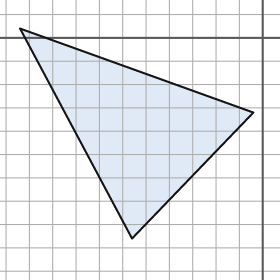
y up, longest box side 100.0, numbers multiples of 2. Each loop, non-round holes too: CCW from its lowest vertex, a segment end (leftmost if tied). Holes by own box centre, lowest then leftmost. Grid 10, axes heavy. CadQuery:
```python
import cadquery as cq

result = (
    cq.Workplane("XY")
    .moveTo(-56.0, -86.0)
    .lineTo(-4.0, -32.0)
    .lineTo(-104.0, 4.0)
    .close()
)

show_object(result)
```